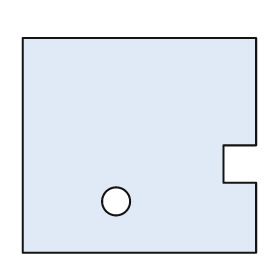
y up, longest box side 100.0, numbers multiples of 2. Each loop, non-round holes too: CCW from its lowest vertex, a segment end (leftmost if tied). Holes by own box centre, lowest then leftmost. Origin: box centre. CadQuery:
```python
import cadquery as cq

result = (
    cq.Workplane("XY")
    .moveTo(-50.0, -46.0)
    .lineTo(50.0, -46.0)
    .lineTo(50.0, -16.0)
    .lineTo(36.0, -16.0)
    .lineTo(36.0, 0.0)
    .lineTo(50.0, 0.0)
    .lineTo(50.0, 46.0)
    .lineTo(-50.0, 46.0)
    .close()
    .moveTo(-10.0, -24.0)
    .circle(6.0)
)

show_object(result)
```